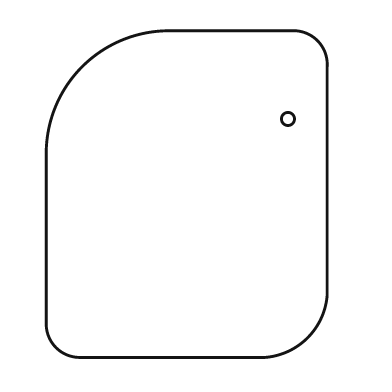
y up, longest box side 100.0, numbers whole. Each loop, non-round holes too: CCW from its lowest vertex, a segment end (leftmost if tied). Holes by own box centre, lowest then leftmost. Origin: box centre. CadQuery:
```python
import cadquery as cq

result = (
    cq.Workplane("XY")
    .moveTo(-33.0, -50.0)
    .lineTo(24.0, -50.0)
    .threePointArc((37.0, -44.0), (43.0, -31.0))
    .lineTo(43.0, 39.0)
    .threePointArc((40.0, 47.0), (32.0, 50.0))
    .lineTo(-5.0, 50.0)
    .threePointArc((-32.0, 39.0), (-43.0, 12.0))
    .lineTo(-43.0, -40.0)
    .threePointArc((-40.0, -47.0), (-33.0, -50.0))
    .close()
    .moveTo(31.0, 23.0)
    .circle(2.0)
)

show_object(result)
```